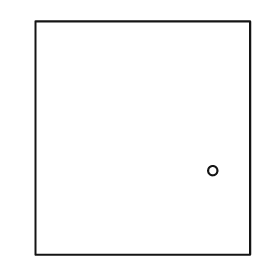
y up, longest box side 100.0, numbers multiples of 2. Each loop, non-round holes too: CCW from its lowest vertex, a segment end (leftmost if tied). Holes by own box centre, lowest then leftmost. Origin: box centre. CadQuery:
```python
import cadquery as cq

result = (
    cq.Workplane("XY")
    .moveTo(-46.0, -50.0)
    .lineTo(46.0, -50.0)
    .lineTo(46.0, 50.0)
    .lineTo(-46.0, 50.0)
    .close()
    .moveTo(30.0, -14.0)
    .circle(2.0)
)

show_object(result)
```